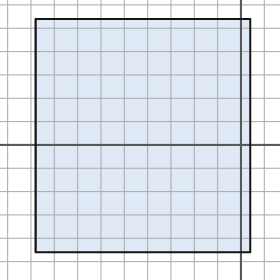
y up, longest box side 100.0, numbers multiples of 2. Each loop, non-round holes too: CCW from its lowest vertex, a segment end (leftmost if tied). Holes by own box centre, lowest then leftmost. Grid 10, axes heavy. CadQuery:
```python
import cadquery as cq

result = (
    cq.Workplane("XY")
    .moveTo(-88.0, -46.0)
    .lineTo(4.0, -46.0)
    .lineTo(4.0, 54.0)
    .lineTo(-88.0, 54.0)
    .close()
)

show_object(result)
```